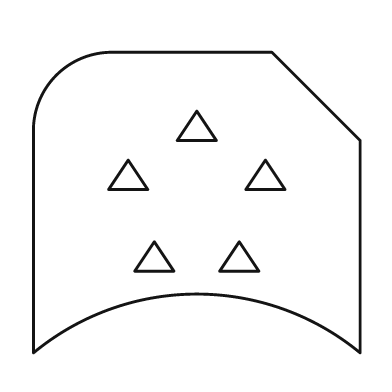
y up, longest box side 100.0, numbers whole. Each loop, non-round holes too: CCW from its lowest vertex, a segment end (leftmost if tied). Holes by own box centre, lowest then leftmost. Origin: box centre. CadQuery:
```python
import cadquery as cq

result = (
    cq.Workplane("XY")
    .moveTo(-50.0, -46.0)
    .threePointArc((0.0, -28.0), (50.0, -46.0))
    .lineTo(50.0, 19.0)
    .lineTo(23.0, 46.0)
    .lineTo(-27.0, 46.0)
    .threePointArc((-43.0, 39.0), (-50.0, 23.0))
    .close()
    .moveTo(-19.0, -21.0)
    .lineTo(-7.0, -21.0)
    .lineTo(-13.0, -12.0)
    .close()
    .moveTo(7.0, -21.0)
    .lineTo(19.0, -21.0)
    .lineTo(13.0, -12.0)
    .close()
    .moveTo(-27.0, 4.0)
    .lineTo(-15.0, 4.0)
    .lineTo(-21.0, 13.0)
    .close()
    .moveTo(15.0, 4.0)
    .lineTo(27.0, 4.0)
    .lineTo(21.0, 13.0)
    .close()
    .moveTo(-6.0, 19.0)
    .lineTo(6.0, 19.0)
    .lineTo(0.0, 28.0)
    .close()
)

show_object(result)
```